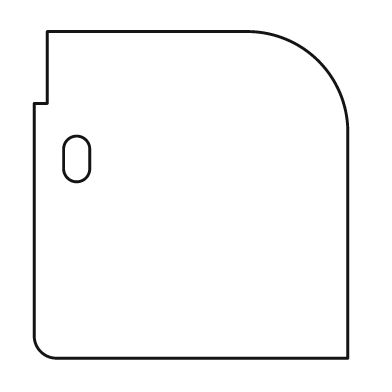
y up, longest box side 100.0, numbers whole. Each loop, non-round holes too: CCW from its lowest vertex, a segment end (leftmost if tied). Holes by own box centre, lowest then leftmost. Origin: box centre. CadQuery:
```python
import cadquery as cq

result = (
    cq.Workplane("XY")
    .moveTo(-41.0, -50.0)
    .lineTo(48.0, -50.0)
    .lineTo(48.0, 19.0)
    .threePointArc((39.0, 41.0), (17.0, 50.0))
    .lineTo(-44.0, 50.0)
    .lineTo(-44.0, 28.0)
    .lineTo(-48.0, 28.0)
    .lineTo(-48.0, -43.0)
    .threePointArc((-46.0, -48.0), (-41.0, -50.0))
    .close()
    .moveTo(-39.0, 8.0)
    .threePointArc((-35.0, 4.0), (-31.0, 8.0))
    .lineTo(-31.0, 14.0)
    .threePointArc((-35.0, 18.0), (-39.0, 14.0))
    .close()
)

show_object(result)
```